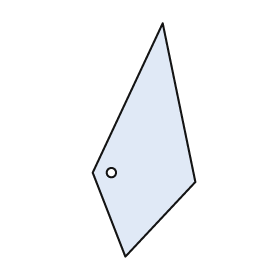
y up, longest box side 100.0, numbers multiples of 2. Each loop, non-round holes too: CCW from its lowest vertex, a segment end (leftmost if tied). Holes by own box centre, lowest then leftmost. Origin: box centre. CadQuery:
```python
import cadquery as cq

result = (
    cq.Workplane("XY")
    .moveTo(-8.0, -50.0)
    .lineTo(22.0, -18.0)
    .lineTo(8.0, 50.0)
    .lineTo(-22.0, -14.0)
    .close()
    .moveTo(-14.0, -14.0)
    .circle(2.0)
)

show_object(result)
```